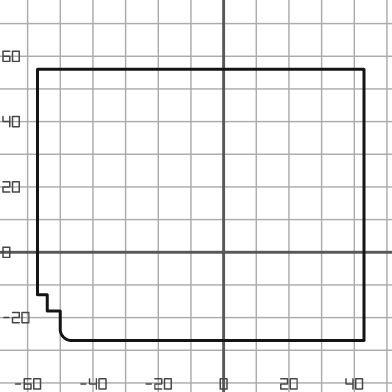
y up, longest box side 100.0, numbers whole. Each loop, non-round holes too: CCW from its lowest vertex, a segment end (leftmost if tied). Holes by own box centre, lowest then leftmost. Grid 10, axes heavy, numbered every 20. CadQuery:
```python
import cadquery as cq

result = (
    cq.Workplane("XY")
    .moveTo(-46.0, -27.0)
    .lineTo(43.0, -27.0)
    .lineTo(43.0, 56.0)
    .lineTo(-57.0, 56.0)
    .lineTo(-57.0, -13.0)
    .lineTo(-54.0, -13.0)
    .lineTo(-54.0, -18.0)
    .lineTo(-50.0, -18.0)
    .lineTo(-50.0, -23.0)
    .threePointArc((-49.0, -26.0), (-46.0, -27.0))
    .close()
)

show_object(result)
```